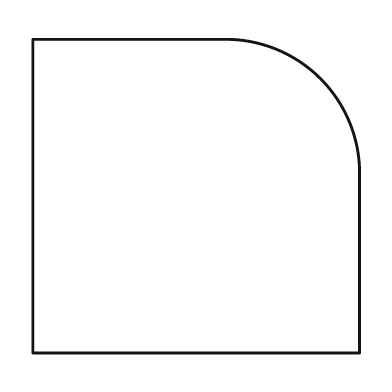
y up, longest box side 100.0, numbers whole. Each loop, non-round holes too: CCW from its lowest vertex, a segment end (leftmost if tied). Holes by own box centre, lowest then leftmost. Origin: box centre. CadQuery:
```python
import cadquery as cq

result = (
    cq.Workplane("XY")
    .moveTo(-50.0, -48.0)
    .lineTo(50.0, -48.0)
    .lineTo(50.0, 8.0)
    .threePointArc((38.0, 36.0), (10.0, 48.0))
    .lineTo(-50.0, 48.0)
    .close()
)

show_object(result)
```